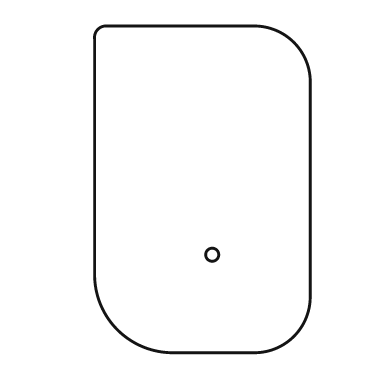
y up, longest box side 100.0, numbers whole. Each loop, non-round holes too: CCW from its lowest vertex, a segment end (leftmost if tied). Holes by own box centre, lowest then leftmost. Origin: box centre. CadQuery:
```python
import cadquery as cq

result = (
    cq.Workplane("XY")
    .moveTo(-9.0, -50.0)
    .lineTo(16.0, -50.0)
    .threePointArc((28.0, -45.0), (33.0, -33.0))
    .lineTo(33.0, 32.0)
    .threePointArc((28.0, 45.0), (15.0, 50.0))
    .lineTo(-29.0, 50.0)
    .threePointArc((-32.0, 49.0), (-33.0, 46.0))
    .lineTo(-33.0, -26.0)
    .threePointArc((-26.0, -43.0), (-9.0, -50.0))
    .close()
    .moveTo(3.0, -20.0)
    .circle(2.0)
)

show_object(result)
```